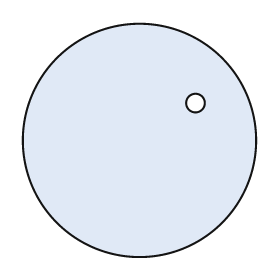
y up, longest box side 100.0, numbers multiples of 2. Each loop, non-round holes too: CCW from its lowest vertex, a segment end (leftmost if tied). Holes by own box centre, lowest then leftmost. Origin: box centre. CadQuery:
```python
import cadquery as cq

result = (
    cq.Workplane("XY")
    .moveTo(0.0, 0.0)
    .circle(50.0)
    .moveTo(24.0, 16.0)
    .circle(4.0)
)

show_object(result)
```